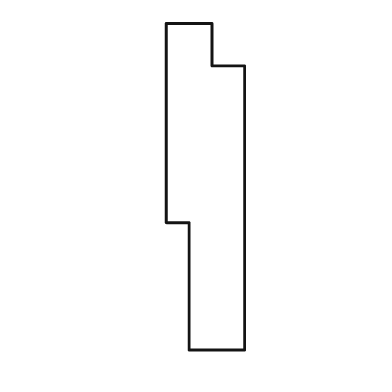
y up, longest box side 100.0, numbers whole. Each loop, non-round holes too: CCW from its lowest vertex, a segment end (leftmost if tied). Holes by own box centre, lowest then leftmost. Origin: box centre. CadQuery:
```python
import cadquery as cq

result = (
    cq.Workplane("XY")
    .moveTo(-5.0, -50.0)
    .lineTo(12.0, -50.0)
    .lineTo(12.0, 37.0)
    .lineTo(2.0, 37.0)
    .lineTo(2.0, 50.0)
    .lineTo(-12.0, 50.0)
    .lineTo(-12.0, -11.0)
    .lineTo(-5.0, -11.0)
    .close()
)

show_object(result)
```